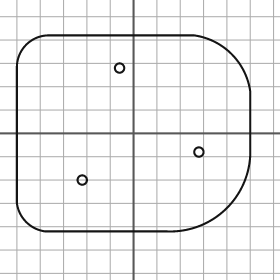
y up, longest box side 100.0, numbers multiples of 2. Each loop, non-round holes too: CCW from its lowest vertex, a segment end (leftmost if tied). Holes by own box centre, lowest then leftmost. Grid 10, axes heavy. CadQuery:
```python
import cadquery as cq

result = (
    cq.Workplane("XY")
    .moveTo(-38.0, -42.0)
    .lineTo(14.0, -42.0)
    .threePointArc((40.0, -32.0), (50.0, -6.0))
    .lineTo(50.0, 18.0)
    .threePointArc((42.0, 34.0), (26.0, 42.0))
    .lineTo(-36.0, 42.0)
    .threePointArc((-46.0, 38.0), (-50.0, 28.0))
    .lineTo(-50.0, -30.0)
    .threePointArc((-46.0, -38.0), (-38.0, -42.0))
    .close()
    .moveTo(-22.0, -20.0)
    .circle(2.0)
    .moveTo(28.0, -8.0)
    .circle(2.0)
    .moveTo(-6.0, 28.0)
    .circle(2.0)
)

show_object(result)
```